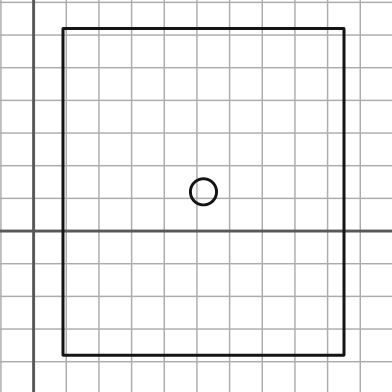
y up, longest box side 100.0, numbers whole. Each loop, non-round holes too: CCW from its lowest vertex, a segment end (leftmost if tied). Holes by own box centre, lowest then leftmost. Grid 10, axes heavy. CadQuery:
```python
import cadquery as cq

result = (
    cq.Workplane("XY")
    .moveTo(9.0, -38.0)
    .lineTo(95.0, -38.0)
    .lineTo(95.0, 62.0)
    .lineTo(9.0, 62.0)
    .close()
    .moveTo(52.0, 12.0)
    .circle(4.0)
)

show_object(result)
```